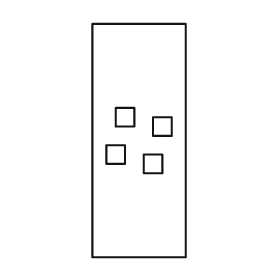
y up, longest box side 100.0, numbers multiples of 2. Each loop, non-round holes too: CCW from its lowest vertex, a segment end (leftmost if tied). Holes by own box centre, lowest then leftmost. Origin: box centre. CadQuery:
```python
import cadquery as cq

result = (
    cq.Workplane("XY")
    .moveTo(-20.0, -50.0)
    .lineTo(20.0, -50.0)
    .lineTo(20.0, 50.0)
    .lineTo(-20.0, 50.0)
    .close()
    .moveTo(2.0, -14.0)
    .lineTo(10.0, -14.0)
    .lineTo(10.0, -6.0)
    .lineTo(2.0, -6.0)
    .close()
    .moveTo(-14.0, -10.0)
    .lineTo(-6.0, -10.0)
    .lineTo(-6.0, -2.0)
    .lineTo(-14.0, -2.0)
    .close()
    .moveTo(6.0, 2.0)
    .lineTo(14.0, 2.0)
    .lineTo(14.0, 10.0)
    .lineTo(6.0, 10.0)
    .close()
    .moveTo(-10.0, 6.0)
    .lineTo(-2.0, 6.0)
    .lineTo(-2.0, 14.0)
    .lineTo(-10.0, 14.0)
    .close()
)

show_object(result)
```